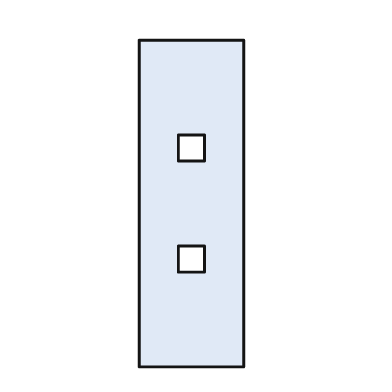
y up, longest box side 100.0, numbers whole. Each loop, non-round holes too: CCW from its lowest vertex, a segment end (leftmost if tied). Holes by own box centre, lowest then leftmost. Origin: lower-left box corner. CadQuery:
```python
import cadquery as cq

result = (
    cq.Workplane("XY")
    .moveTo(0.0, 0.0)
    .lineTo(32.0, 0.0)
    .lineTo(32.0, 100.0)
    .lineTo(0.0, 100.0)
    .close()
    .moveTo(12.0, 29.0)
    .lineTo(20.0, 29.0)
    .lineTo(20.0, 37.0)
    .lineTo(12.0, 37.0)
    .close()
    .moveTo(12.0, 63.0)
    .lineTo(20.0, 63.0)
    .lineTo(20.0, 71.0)
    .lineTo(12.0, 71.0)
    .close()
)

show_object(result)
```